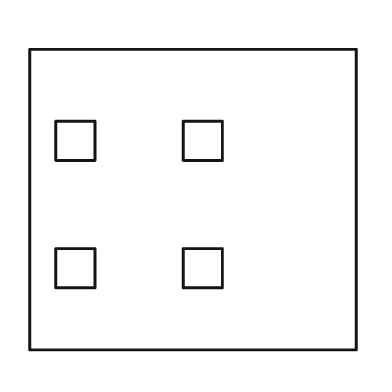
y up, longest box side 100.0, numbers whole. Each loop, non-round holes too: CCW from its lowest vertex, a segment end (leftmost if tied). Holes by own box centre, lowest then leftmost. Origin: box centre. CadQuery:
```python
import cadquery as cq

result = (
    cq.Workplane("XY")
    .moveTo(-50.0, -46.0)
    .lineTo(50.0, -46.0)
    .lineTo(50.0, 46.0)
    .lineTo(-50.0, 46.0)
    .close()
    .moveTo(-42.0, -27.0)
    .lineTo(-30.0, -27.0)
    .lineTo(-30.0, -15.0)
    .lineTo(-42.0, -15.0)
    .close()
    .moveTo(-3.0, -27.0)
    .lineTo(9.0, -27.0)
    .lineTo(9.0, -15.0)
    .lineTo(-3.0, -15.0)
    .close()
    .moveTo(-42.0, 12.0)
    .lineTo(-30.0, 12.0)
    .lineTo(-30.0, 24.0)
    .lineTo(-42.0, 24.0)
    .close()
    .moveTo(-3.0, 12.0)
    .lineTo(9.0, 12.0)
    .lineTo(9.0, 24.0)
    .lineTo(-3.0, 24.0)
    .close()
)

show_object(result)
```